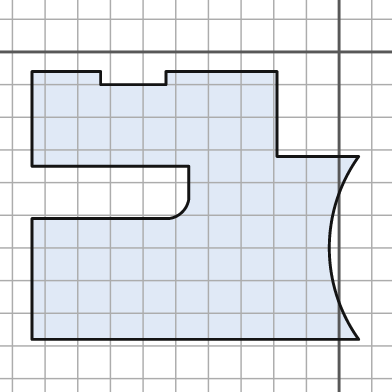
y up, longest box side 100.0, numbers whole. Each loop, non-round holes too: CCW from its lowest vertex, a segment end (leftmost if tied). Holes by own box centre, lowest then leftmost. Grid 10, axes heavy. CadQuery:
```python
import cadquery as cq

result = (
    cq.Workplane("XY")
    .moveTo(-94.0, -88.0)
    .lineTo(6.0, -88.0)
    .threePointArc((-3.0, -60.0), (6.0, -32.0))
    .lineTo(-19.0, -32.0)
    .lineTo(-19.0, -6.0)
    .lineTo(-53.0, -6.0)
    .lineTo(-53.0, -10.0)
    .lineTo(-73.0, -10.0)
    .lineTo(-73.0, -6.0)
    .lineTo(-94.0, -6.0)
    .lineTo(-94.0, -35.0)
    .lineTo(-46.0, -35.0)
    .lineTo(-46.0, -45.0)
    .threePointArc((-48.0, -49.0), (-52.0, -51.0))
    .lineTo(-94.0, -51.0)
    .close()
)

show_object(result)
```